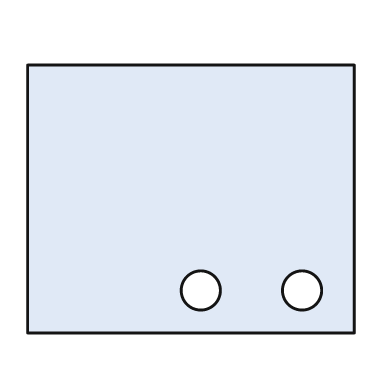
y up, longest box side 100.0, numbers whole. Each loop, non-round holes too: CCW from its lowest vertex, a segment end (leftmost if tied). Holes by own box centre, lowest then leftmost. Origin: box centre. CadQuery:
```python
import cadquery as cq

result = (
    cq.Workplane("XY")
    .moveTo(-50.0, -41.0)
    .lineTo(50.0, -41.0)
    .lineTo(50.0, 41.0)
    .lineTo(-50.0, 41.0)
    .close()
    .moveTo(3.0, -28.0)
    .circle(6.0)
    .moveTo(34.0, -28.0)
    .circle(6.0)
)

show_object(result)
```